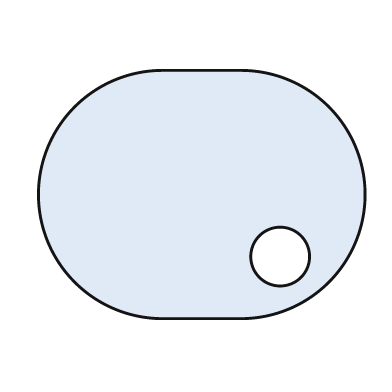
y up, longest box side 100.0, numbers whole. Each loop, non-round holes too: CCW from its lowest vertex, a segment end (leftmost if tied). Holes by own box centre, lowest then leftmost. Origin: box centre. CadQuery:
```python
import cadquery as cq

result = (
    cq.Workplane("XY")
    .moveTo(-12.0, -38.0)
    .lineTo(12.0, -38.0)
    .threePointArc((50.0, 0.0), (12.0, 38.0))
    .lineTo(-12.0, 38.0)
    .threePointArc((-50.0, 0.0), (-12.0, -38.0))
    .close()
    .moveTo(24.0, -19.0)
    .circle(9.0)
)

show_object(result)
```